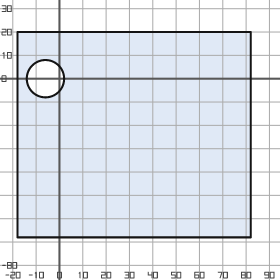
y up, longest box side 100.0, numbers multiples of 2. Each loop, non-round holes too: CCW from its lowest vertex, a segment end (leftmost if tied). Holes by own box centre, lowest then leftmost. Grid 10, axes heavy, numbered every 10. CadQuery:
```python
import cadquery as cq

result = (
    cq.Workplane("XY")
    .moveTo(-18.0, -68.0)
    .lineTo(82.0, -68.0)
    .lineTo(82.0, 20.0)
    .lineTo(-18.0, 20.0)
    .close()
    .moveTo(-6.0, 0.0)
    .circle(8.0)
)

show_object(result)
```